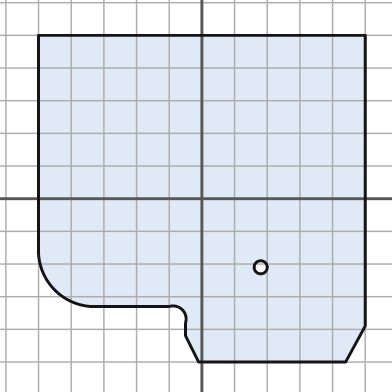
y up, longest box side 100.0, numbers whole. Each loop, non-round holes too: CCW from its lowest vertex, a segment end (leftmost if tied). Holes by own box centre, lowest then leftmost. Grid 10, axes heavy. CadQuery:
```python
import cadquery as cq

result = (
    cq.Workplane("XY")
    .moveTo(-1.0, -50.0)
    .lineTo(44.0, -50.0)
    .lineTo(50.0, -39.0)
    .lineTo(50.0, 50.0)
    .lineTo(-50.0, 50.0)
    .lineTo(-50.0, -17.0)
    .threePointArc((-45.0, -28.0), (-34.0, -33.0))
    .lineTo(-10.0, -33.0)
    .threePointArc((-6.0, -34.0), (-5.0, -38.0))
    .lineTo(-5.0, -42.0)
    .close()
    .moveTo(18.0, -21.0)
    .circle(2.0)
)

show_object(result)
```